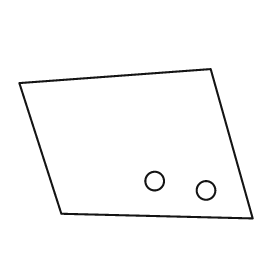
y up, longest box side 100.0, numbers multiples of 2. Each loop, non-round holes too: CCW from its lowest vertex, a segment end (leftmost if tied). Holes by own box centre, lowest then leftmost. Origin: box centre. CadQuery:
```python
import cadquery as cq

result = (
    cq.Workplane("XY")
    .moveTo(50.0, -32.0)
    .lineTo(32.0, 32.0)
    .lineTo(-50.0, 26.0)
    .lineTo(-32.0, -30.0)
    .close()
    .moveTo(30.0, -20.0)
    .circle(4.0)
    .moveTo(8.0, -16.0)
    .circle(4.0)
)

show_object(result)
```